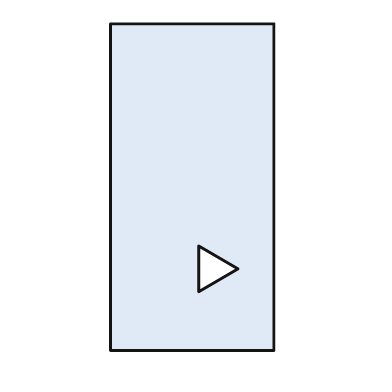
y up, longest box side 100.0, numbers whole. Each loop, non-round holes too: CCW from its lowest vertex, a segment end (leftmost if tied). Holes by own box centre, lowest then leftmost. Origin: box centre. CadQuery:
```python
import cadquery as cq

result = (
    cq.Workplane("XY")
    .moveTo(-25.0, -50.0)
    .lineTo(25.0, -50.0)
    .lineTo(25.0, 50.0)
    .lineTo(-25.0, 50.0)
    .close()
    .moveTo(2.0, -32.0)
    .lineTo(14.0, -25.0)
    .lineTo(2.0, -18.0)
    .close()
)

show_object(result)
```